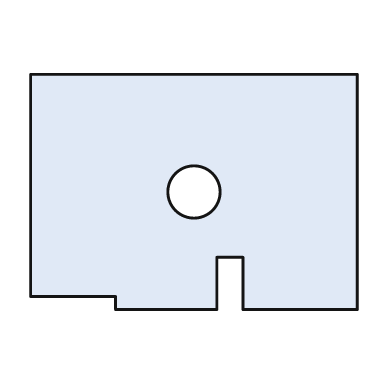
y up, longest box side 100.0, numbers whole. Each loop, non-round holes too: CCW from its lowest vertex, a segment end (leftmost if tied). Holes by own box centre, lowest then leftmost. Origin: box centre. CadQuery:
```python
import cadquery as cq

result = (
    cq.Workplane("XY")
    .moveTo(-24.0, -36.0)
    .lineTo(7.0, -36.0)
    .lineTo(7.0, -20.0)
    .lineTo(15.0, -20.0)
    .lineTo(15.0, -36.0)
    .lineTo(50.0, -36.0)
    .lineTo(50.0, 36.0)
    .lineTo(-50.0, 36.0)
    .lineTo(-50.0, -32.0)
    .lineTo(-24.0, -32.0)
    .close()
    .moveTo(0.0, 0.0)
    .circle(8.0)
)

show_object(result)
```